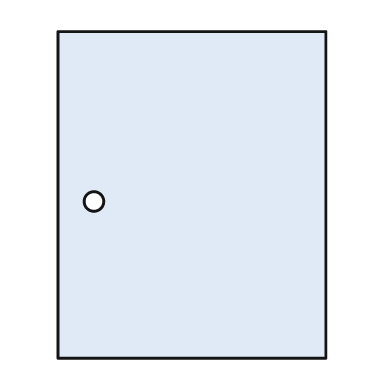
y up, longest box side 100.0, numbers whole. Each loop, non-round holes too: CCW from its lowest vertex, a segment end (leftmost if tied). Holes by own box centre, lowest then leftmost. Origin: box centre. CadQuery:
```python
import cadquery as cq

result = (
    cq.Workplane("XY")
    .moveTo(-41.0, -50.0)
    .lineTo(41.0, -50.0)
    .lineTo(41.0, 50.0)
    .lineTo(-41.0, 50.0)
    .close()
    .moveTo(-30.0, -2.0)
    .circle(3.0)
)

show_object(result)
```